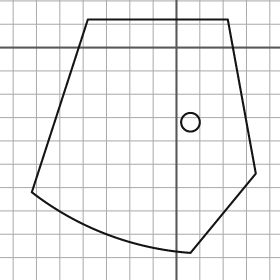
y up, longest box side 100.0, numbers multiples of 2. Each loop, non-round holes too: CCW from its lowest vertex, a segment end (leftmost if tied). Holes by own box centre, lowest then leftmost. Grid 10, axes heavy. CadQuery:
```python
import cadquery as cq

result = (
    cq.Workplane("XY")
    .moveTo(6.0, -88.0)
    .lineTo(34.0, -54.0)
    .lineTo(22.0, 12.0)
    .lineTo(-38.0, 12.0)
    .lineTo(-62.0, -62.0)
    .threePointArc((-30.0, -80.0), (6.0, -88.0))
    .close()
    .moveTo(6.0, -32.0)
    .circle(4.0)
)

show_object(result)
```